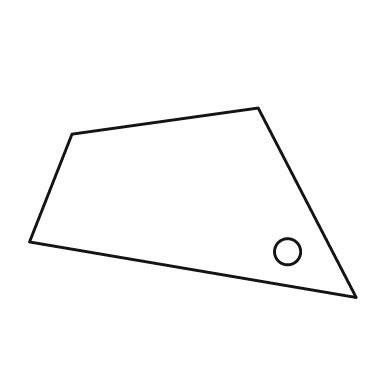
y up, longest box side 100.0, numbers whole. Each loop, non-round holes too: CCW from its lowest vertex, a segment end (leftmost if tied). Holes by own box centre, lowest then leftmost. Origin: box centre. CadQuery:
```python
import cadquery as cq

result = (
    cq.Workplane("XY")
    .moveTo(50.0, -29.0)
    .lineTo(20.0, 29.0)
    .lineTo(-37.0, 21.0)
    .lineTo(-50.0, -12.0)
    .close()
    .moveTo(29.0, -15.0)
    .circle(4.0)
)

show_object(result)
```